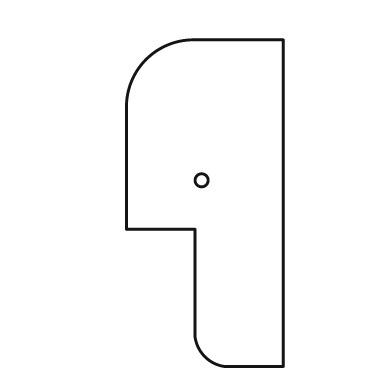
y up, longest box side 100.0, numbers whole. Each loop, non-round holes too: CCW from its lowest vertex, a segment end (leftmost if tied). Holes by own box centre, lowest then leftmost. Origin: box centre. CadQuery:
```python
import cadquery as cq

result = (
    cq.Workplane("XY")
    .moveTo(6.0, -50.0)
    .lineTo(24.0, -50.0)
    .lineTo(24.0, 50.0)
    .lineTo(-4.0, 50.0)
    .threePointArc((-18.0, 44.0), (-24.0, 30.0))
    .lineTo(-24.0, -8.0)
    .lineTo(-3.0, -8.0)
    .lineTo(-3.0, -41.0)
    .threePointArc((0.0, -47.0), (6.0, -50.0))
    .close()
    .moveTo(-1.0, 7.0)
    .circle(2.0)
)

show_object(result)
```